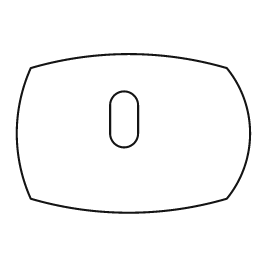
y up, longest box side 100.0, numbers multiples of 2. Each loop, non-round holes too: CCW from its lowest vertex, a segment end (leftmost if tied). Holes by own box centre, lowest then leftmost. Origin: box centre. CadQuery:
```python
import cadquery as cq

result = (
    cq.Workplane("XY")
    .moveTo(-44.0, -28.0)
    .threePointArc((-2.0, -34.0), (40.0, -28.0))
    .threePointArc((50.0, 0.0), (40.0, 28.0))
    .threePointArc((-2.0, 34.0), (-44.0, 28.0))
    .threePointArc((-50.0, 0.0), (-44.0, -28.0))
    .close()
    .moveTo(-10.0, 0.0)
    .threePointArc((-4.0, -6.0), (2.0, 0.0))
    .lineTo(2.0, 12.0)
    .threePointArc((-4.0, 18.0), (-10.0, 12.0))
    .close()
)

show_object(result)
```